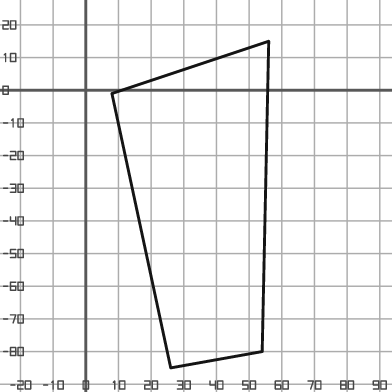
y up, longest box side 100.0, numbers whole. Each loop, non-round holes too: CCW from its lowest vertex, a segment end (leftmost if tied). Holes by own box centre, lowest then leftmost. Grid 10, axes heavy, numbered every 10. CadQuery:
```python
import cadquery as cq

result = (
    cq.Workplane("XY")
    .moveTo(26.0, -85.0)
    .lineTo(54.0, -80.0)
    .lineTo(56.0, 15.0)
    .lineTo(8.0, -1.0)
    .close()
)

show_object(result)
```